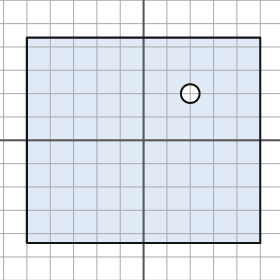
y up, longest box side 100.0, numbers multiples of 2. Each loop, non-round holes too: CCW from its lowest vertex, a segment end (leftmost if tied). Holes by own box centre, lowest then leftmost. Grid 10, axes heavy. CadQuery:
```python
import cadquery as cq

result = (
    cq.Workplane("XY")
    .moveTo(-50.0, -44.0)
    .lineTo(50.0, -44.0)
    .lineTo(50.0, 44.0)
    .lineTo(-50.0, 44.0)
    .close()
    .moveTo(20.0, 20.0)
    .circle(4.0)
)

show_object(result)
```